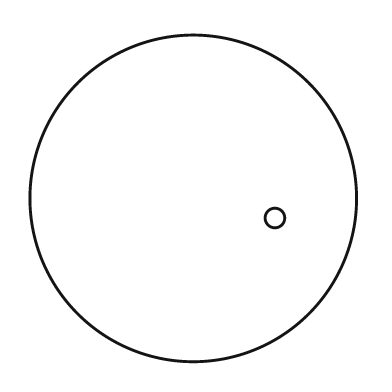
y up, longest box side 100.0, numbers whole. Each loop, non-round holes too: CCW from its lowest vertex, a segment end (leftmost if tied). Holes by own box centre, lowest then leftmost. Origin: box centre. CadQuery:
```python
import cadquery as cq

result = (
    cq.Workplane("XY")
    .moveTo(0.0, 0.0)
    .circle(50.0)
    .moveTo(25.0, -6.0)
    .circle(3.0)
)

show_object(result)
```